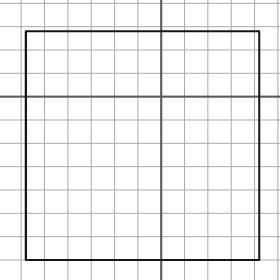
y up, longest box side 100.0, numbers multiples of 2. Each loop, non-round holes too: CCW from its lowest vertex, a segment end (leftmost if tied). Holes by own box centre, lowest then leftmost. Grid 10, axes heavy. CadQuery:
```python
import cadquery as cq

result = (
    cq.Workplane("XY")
    .moveTo(-58.0, -70.0)
    .lineTo(42.0, -70.0)
    .lineTo(42.0, 28.0)
    .lineTo(-58.0, 28.0)
    .close()
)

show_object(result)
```